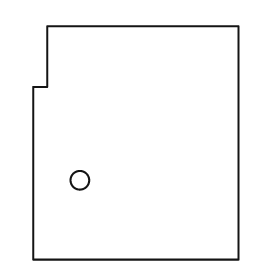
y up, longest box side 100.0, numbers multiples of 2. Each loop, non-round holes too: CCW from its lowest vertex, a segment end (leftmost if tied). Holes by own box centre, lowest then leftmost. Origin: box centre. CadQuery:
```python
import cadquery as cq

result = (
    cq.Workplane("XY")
    .moveTo(-44.0, -50.0)
    .lineTo(44.0, -50.0)
    .lineTo(44.0, 50.0)
    .lineTo(-38.0, 50.0)
    .lineTo(-38.0, 24.0)
    .lineTo(-44.0, 24.0)
    .close()
    .moveTo(-24.0, -16.0)
    .circle(4.0)
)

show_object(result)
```